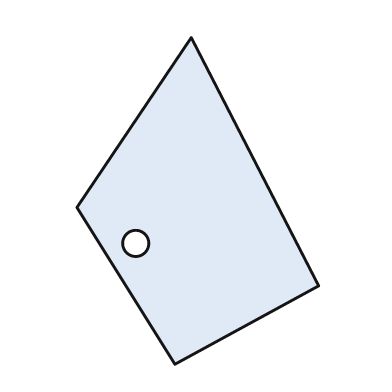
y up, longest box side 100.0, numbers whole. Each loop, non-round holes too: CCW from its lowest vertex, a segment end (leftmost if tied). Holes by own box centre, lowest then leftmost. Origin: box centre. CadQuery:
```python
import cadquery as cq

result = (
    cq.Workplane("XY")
    .moveTo(-7.0, -50.0)
    .lineTo(37.0, -26.0)
    .lineTo(-2.0, 50.0)
    .lineTo(-37.0, -2.0)
    .close()
    .moveTo(-19.0, -13.0)
    .circle(4.0)
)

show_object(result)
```